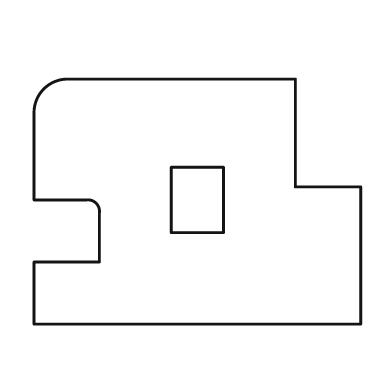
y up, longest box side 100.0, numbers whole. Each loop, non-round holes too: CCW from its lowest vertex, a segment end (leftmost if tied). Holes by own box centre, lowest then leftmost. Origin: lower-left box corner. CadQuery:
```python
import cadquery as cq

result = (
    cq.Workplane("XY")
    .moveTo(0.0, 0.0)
    .lineTo(100.0, 0.0)
    .lineTo(100.0, 42.0)
    .lineTo(80.0, 42.0)
    .lineTo(80.0, 75.0)
    .lineTo(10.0, 75.0)
    .threePointArc((3.0, 72.0), (0.0, 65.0))
    .lineTo(0.0, 38.0)
    .lineTo(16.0, 38.0)
    .threePointArc((19.0, 37.0), (20.0, 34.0))
    .lineTo(20.0, 19.0)
    .lineTo(0.0, 19.0)
    .close()
    .moveTo(42.0, 28.0)
    .lineTo(58.0, 28.0)
    .lineTo(58.0, 48.0)
    .lineTo(42.0, 48.0)
    .close()
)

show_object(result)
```